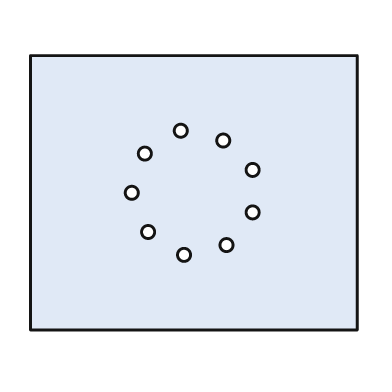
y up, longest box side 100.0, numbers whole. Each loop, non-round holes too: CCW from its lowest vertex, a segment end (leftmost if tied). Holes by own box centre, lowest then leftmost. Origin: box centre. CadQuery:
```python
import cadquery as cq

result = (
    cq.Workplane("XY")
    .moveTo(-50.0, -42.0)
    .lineTo(50.0, -42.0)
    .lineTo(50.0, 42.0)
    .lineTo(-50.0, 42.0)
    .close()
    .moveTo(-3.0, -19.0)
    .circle(2.0)
    .moveTo(10.0, -16.0)
    .circle(2.0)
    .moveTo(-14.0, -12.0)
    .circle(2.0)
    .moveTo(18.0, -6.0)
    .circle(2.0)
    .moveTo(-19.0, 0.0)
    .circle(2.0)
    .moveTo(18.0, 7.0)
    .circle(2.0)
    .moveTo(-15.0, 12.0)
    .circle(2.0)
    .moveTo(9.0, 16.0)
    .circle(2.0)
    .moveTo(-4.0, 19.0)
    .circle(2.0)
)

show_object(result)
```